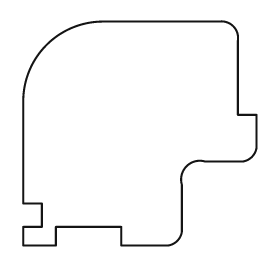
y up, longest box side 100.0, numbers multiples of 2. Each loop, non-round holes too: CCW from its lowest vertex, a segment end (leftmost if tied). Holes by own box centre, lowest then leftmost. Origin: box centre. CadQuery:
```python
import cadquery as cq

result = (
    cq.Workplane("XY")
    .moveTo(-50.0, -48.0)
    .lineTo(-36.0, -48.0)
    .lineTo(-36.0, -40.0)
    .lineTo(-8.0, -40.0)
    .lineTo(-8.0, -48.0)
    .lineTo(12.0, -48.0)
    .threePointArc((16.0, -46.0), (18.0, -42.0))
    .lineTo(18.0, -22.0)
    .threePointArc((20.0, -14.0), (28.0, -12.0))
    .lineTo(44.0, -12.0)
    .threePointArc((48.0, -10.0), (50.0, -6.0))
    .lineTo(50.0, 8.0)
    .lineTo(42.0, 8.0)
    .lineTo(42.0, 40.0)
    .threePointArc((40.0, 46.0), (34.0, 48.0))
    .lineTo(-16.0, 48.0)
    .threePointArc((-40.0, 38.0), (-50.0, 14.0))
    .lineTo(-50.0, -30.0)
    .lineTo(-42.0, -30.0)
    .lineTo(-42.0, -40.0)
    .lineTo(-50.0, -40.0)
    .close()
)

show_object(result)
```